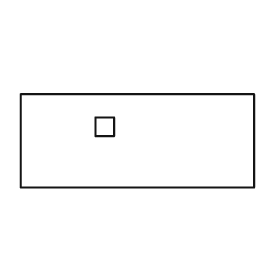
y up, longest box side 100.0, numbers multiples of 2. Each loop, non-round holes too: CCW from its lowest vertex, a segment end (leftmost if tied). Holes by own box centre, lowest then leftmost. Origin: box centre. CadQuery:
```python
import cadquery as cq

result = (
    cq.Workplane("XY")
    .moveTo(-50.0, -20.0)
    .lineTo(50.0, -20.0)
    .lineTo(50.0, 20.0)
    .lineTo(-50.0, 20.0)
    .close()
    .moveTo(-18.0, 2.0)
    .lineTo(-10.0, 2.0)
    .lineTo(-10.0, 10.0)
    .lineTo(-18.0, 10.0)
    .close()
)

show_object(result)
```